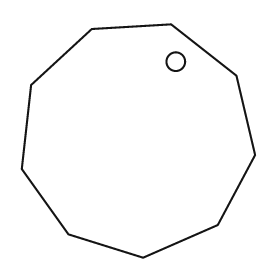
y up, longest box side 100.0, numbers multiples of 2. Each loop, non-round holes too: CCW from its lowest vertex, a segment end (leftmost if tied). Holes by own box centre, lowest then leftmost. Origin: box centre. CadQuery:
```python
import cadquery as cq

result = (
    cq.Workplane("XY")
    .moveTo(2.0, -50.0)
    .lineTo(34.0, -36.0)
    .lineTo(50.0, -6.0)
    .lineTo(42.0, 28.0)
    .lineTo(14.0, 50.0)
    .lineTo(-20.0, 48.0)
    .lineTo(-46.0, 24.0)
    .lineTo(-50.0, -12.0)
    .lineTo(-30.0, -40.0)
    .close()
    .moveTo(16.0, 34.0)
    .circle(4.0)
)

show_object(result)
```